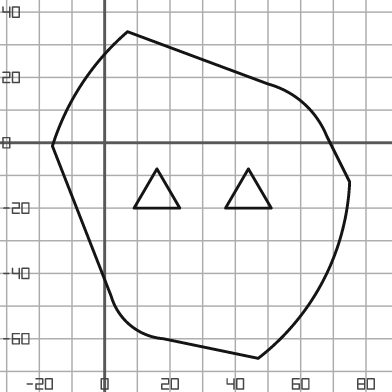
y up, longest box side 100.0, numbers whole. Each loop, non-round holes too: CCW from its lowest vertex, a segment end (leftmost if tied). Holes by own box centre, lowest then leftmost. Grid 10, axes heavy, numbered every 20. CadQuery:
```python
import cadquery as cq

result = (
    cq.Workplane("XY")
    .moveTo(47.0, -66.0)
    .threePointArc((67.0, -42.0), (75.0, -12.0))
    .lineTo(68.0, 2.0)
    .threePointArc((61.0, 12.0), (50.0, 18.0))
    .lineTo(7.0, 34.0)
    .threePointArc((-7.0, 18.0), (-16.0, -1.0))
    .lineTo(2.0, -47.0)
    .threePointArc((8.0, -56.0), (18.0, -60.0))
    .close()
    .moveTo(9.0, -20.0)
    .lineTo(23.0, -20.0)
    .lineTo(16.0, -8.0)
    .close()
    .moveTo(37.0, -20.0)
    .lineTo(51.0, -20.0)
    .lineTo(44.0, -8.0)
    .close()
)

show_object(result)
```